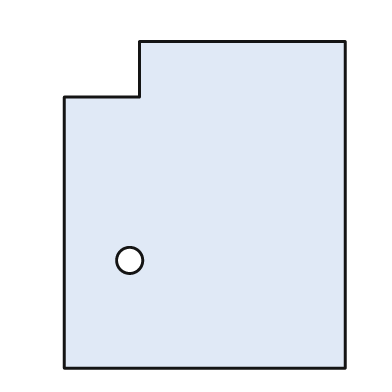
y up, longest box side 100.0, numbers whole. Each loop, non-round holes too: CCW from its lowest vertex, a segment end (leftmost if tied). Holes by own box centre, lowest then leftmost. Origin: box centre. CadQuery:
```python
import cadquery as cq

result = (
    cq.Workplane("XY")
    .moveTo(-43.0, -50.0)
    .lineTo(43.0, -50.0)
    .lineTo(43.0, 50.0)
    .lineTo(-20.0, 50.0)
    .lineTo(-20.0, 33.0)
    .lineTo(-43.0, 33.0)
    .close()
    .moveTo(-23.0, -17.0)
    .circle(4.0)
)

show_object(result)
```